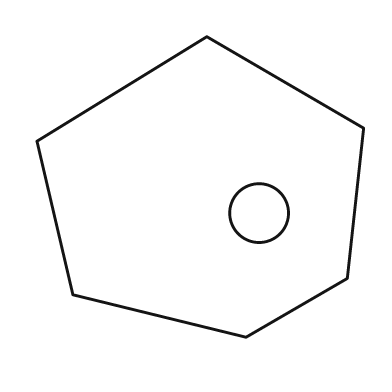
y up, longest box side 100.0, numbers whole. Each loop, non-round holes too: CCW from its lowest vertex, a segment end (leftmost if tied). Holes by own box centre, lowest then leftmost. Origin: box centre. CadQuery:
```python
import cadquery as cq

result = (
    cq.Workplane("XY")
    .moveTo(14.0, -46.0)
    .lineTo(45.0, -28.0)
    .lineTo(50.0, 18.0)
    .lineTo(2.0, 46.0)
    .lineTo(-50.0, 14.0)
    .lineTo(-39.0, -33.0)
    .close()
    .moveTo(18.0, -8.0)
    .circle(9.0)
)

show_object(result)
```